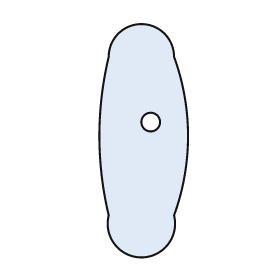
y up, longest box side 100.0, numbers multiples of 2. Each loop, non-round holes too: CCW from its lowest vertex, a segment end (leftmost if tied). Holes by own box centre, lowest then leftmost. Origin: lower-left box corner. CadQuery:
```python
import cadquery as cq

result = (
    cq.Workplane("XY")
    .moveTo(4.0, 18.0)
    .threePointArc((18.0, 0.0), (32.0, 18.0))
    .threePointArc((38.0, 52.0), (32.0, 86.0))
    .threePointArc((18.0, 100.0), (4.0, 86.0))
    .threePointArc((0.0, 52.0), (4.0, 18.0))
    .close()
    .moveTo(22.0, 58.0)
    .circle(4.0)
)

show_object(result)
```